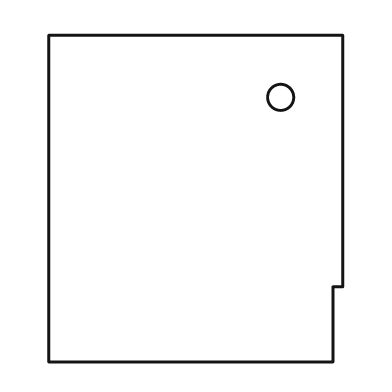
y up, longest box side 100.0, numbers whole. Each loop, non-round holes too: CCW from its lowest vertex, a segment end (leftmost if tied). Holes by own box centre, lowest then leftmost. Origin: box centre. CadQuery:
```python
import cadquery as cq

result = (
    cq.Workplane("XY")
    .moveTo(-45.0, -50.0)
    .lineTo(42.0, -50.0)
    .lineTo(42.0, -27.0)
    .lineTo(45.0, -27.0)
    .lineTo(45.0, 50.0)
    .lineTo(-45.0, 50.0)
    .close()
    .moveTo(26.0, 31.0)
    .circle(4.0)
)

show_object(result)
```